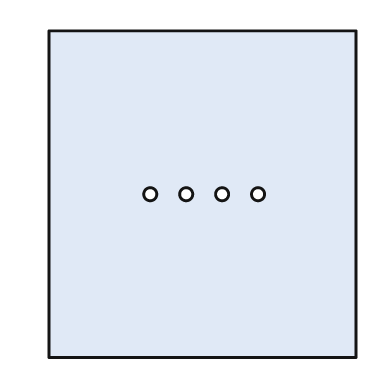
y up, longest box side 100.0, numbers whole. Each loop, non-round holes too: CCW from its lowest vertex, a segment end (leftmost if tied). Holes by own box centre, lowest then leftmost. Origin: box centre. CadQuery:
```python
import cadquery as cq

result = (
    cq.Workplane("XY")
    .moveTo(-47.0, -50.0)
    .lineTo(47.0, -50.0)
    .lineTo(47.0, 50.0)
    .lineTo(-47.0, 50.0)
    .close()
    .moveTo(-16.0, 0.0)
    .circle(2.0)
    .moveTo(-5.0, 0.0)
    .circle(2.0)
    .moveTo(6.0, 0.0)
    .circle(2.0)
    .moveTo(17.0, 0.0)
    .circle(2.0)
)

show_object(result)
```